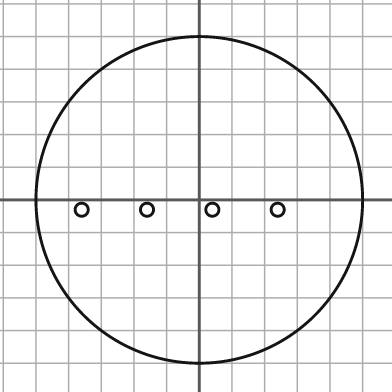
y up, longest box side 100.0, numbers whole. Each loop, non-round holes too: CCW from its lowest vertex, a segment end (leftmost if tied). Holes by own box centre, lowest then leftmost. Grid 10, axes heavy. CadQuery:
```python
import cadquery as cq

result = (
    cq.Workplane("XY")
    .moveTo(0.0, 0.0)
    .circle(50.0)
    .moveTo(-36.0, -3.0)
    .circle(2.0)
    .moveTo(-16.0, -3.0)
    .circle(2.0)
    .moveTo(4.0, -3.0)
    .circle(2.0)
    .moveTo(24.0, -3.0)
    .circle(2.0)
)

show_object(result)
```